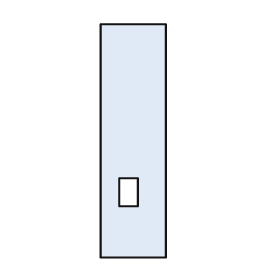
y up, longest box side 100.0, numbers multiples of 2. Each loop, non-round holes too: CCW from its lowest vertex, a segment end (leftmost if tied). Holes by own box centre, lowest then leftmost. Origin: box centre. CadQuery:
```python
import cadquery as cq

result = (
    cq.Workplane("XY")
    .moveTo(-14.0, -50.0)
    .lineTo(14.0, -50.0)
    .lineTo(14.0, 50.0)
    .lineTo(-14.0, 50.0)
    .close()
    .moveTo(-6.0, -28.0)
    .lineTo(2.0, -28.0)
    .lineTo(2.0, -16.0)
    .lineTo(-6.0, -16.0)
    .close()
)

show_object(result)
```